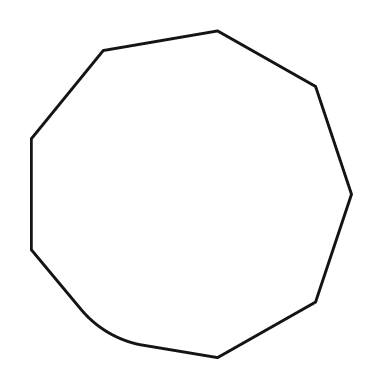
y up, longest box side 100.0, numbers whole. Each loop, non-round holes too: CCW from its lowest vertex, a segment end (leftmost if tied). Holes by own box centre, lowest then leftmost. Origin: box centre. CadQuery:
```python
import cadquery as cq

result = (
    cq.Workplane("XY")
    .moveTo(8.0, -50.0)
    .lineTo(38.0, -33.0)
    .lineTo(49.0, 0.0)
    .lineTo(38.0, 33.0)
    .lineTo(8.0, 50.0)
    .lineTo(-27.0, 44.0)
    .lineTo(-49.0, 17.0)
    .lineTo(-49.0, -17.0)
    .lineTo(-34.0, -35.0)
    .threePointArc((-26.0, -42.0), (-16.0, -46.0))
    .close()
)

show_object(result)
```